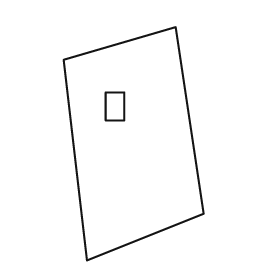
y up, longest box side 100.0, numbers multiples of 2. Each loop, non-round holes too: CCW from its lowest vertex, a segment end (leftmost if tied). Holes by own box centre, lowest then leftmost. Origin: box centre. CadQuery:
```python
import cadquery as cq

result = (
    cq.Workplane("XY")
    .moveTo(-20.0, -50.0)
    .lineTo(30.0, -30.0)
    .lineTo(18.0, 50.0)
    .lineTo(-30.0, 36.0)
    .close()
    .moveTo(-12.0, 10.0)
    .lineTo(-4.0, 10.0)
    .lineTo(-4.0, 22.0)
    .lineTo(-12.0, 22.0)
    .close()
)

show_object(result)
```